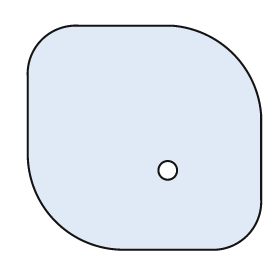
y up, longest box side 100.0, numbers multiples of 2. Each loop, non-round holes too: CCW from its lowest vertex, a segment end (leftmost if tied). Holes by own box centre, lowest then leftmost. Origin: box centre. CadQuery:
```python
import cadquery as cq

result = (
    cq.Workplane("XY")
    .moveTo(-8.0, -48.0)
    .lineTo(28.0, -48.0)
    .threePointArc((44.0, -42.0), (50.0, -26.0))
    .lineTo(50.0, 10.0)
    .threePointArc((38.0, 36.0), (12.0, 48.0))
    .lineTo(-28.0, 48.0)
    .threePointArc((-44.0, 42.0), (-50.0, 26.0))
    .lineTo(-50.0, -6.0)
    .threePointArc((-38.0, -36.0), (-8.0, -48.0))
    .close()
    .moveTo(10.0, -14.0)
    .circle(4.0)
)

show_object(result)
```